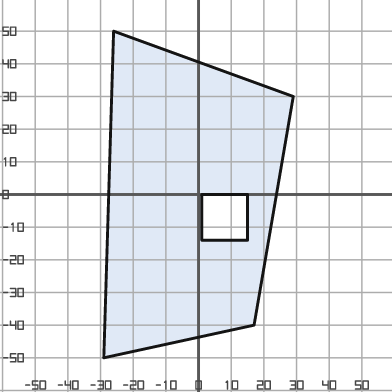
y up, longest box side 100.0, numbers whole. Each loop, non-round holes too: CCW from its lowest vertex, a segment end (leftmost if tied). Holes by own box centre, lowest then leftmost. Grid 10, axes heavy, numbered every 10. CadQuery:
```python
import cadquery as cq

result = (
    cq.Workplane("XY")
    .moveTo(-29.0, -50.0)
    .lineTo(17.0, -40.0)
    .lineTo(29.0, 30.0)
    .lineTo(-26.0, 50.0)
    .close()
    .moveTo(1.0, -14.0)
    .lineTo(15.0, -14.0)
    .lineTo(15.0, 0.0)
    .lineTo(1.0, 0.0)
    .close()
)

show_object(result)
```